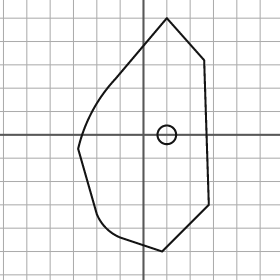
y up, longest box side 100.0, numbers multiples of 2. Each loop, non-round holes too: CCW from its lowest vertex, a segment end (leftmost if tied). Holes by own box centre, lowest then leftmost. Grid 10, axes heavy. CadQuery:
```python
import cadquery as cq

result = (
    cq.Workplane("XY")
    .moveTo(8.0, -50.0)
    .lineTo(28.0, -30.0)
    .lineTo(26.0, 32.0)
    .lineTo(10.0, 50.0)
    .lineTo(-12.0, 24.0)
    .threePointArc((-22.0, 10.0), (-28.0, -6.0))
    .lineTo(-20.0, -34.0)
    .threePointArc((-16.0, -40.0), (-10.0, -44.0))
    .close()
    .moveTo(10.0, 0.0)
    .circle(4.0)
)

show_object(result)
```